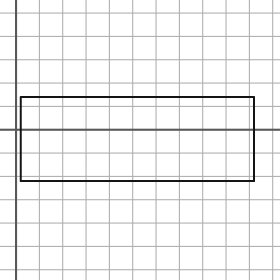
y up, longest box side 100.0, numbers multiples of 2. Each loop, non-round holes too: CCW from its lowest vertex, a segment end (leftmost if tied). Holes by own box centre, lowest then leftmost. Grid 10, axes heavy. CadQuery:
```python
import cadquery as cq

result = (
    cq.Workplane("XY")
    .moveTo(2.0, -22.0)
    .lineTo(102.0, -22.0)
    .lineTo(102.0, 14.0)
    .lineTo(2.0, 14.0)
    .close()
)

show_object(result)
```